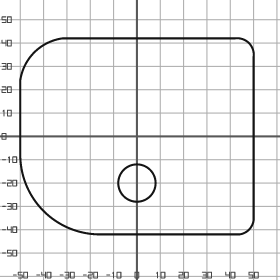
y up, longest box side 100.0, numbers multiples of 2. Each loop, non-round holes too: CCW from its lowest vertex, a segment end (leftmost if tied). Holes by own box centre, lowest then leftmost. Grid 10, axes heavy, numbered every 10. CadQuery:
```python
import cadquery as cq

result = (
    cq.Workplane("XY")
    .moveTo(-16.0, -42.0)
    .lineTo(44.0, -42.0)
    .threePointArc((48.0, -40.0), (50.0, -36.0))
    .lineTo(50.0, 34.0)
    .threePointArc((48.0, 40.0), (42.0, 42.0))
    .lineTo(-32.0, 42.0)
    .threePointArc((-44.0, 36.0), (-50.0, 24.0))
    .lineTo(-50.0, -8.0)
    .threePointArc((-40.0, -32.0), (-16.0, -42.0))
    .close()
    .moveTo(0.0, -20.0)
    .circle(8.0)
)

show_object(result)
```